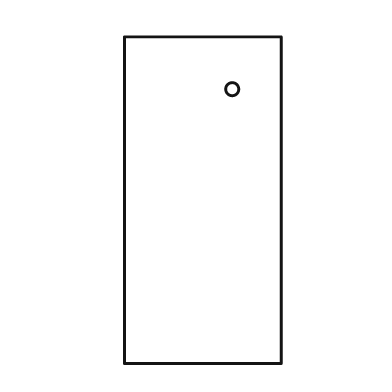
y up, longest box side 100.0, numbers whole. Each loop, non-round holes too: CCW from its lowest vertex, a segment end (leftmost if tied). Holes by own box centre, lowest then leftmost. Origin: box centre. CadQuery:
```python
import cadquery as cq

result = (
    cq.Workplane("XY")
    .moveTo(-24.0, -50.0)
    .lineTo(24.0, -50.0)
    .lineTo(24.0, 50.0)
    .lineTo(-24.0, 50.0)
    .close()
    .moveTo(9.0, 34.0)
    .circle(2.0)
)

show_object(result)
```